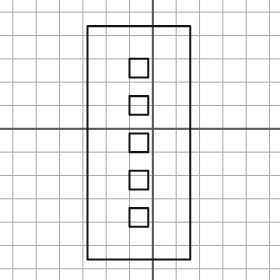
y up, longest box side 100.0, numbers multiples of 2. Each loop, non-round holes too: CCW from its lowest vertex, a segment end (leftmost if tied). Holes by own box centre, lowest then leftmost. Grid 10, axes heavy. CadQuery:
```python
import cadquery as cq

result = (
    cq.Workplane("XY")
    .moveTo(-28.0, -56.0)
    .lineTo(16.0, -56.0)
    .lineTo(16.0, 44.0)
    .lineTo(-28.0, 44.0)
    .close()
    .moveTo(-10.0, -42.0)
    .lineTo(-2.0, -42.0)
    .lineTo(-2.0, -34.0)
    .lineTo(-10.0, -34.0)
    .close()
    .moveTo(-10.0, -26.0)
    .lineTo(-2.0, -26.0)
    .lineTo(-2.0, -18.0)
    .lineTo(-10.0, -18.0)
    .close()
    .moveTo(-10.0, -10.0)
    .lineTo(-2.0, -10.0)
    .lineTo(-2.0, -2.0)
    .lineTo(-10.0, -2.0)
    .close()
    .moveTo(-10.0, 6.0)
    .lineTo(-2.0, 6.0)
    .lineTo(-2.0, 14.0)
    .lineTo(-10.0, 14.0)
    .close()
    .moveTo(-10.0, 22.0)
    .lineTo(-2.0, 22.0)
    .lineTo(-2.0, 30.0)
    .lineTo(-10.0, 30.0)
    .close()
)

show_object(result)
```